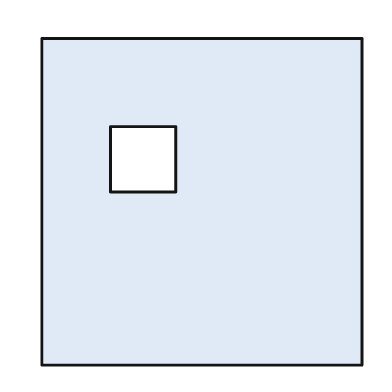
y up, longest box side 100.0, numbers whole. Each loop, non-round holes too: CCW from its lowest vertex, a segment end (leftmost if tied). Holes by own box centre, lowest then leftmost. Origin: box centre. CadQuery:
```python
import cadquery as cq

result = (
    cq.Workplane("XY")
    .moveTo(-49.0, -50.0)
    .lineTo(49.0, -50.0)
    .lineTo(49.0, 50.0)
    .lineTo(-49.0, 50.0)
    .close()
    .moveTo(-28.0, 3.0)
    .lineTo(-8.0, 3.0)
    .lineTo(-8.0, 23.0)
    .lineTo(-28.0, 23.0)
    .close()
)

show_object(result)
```